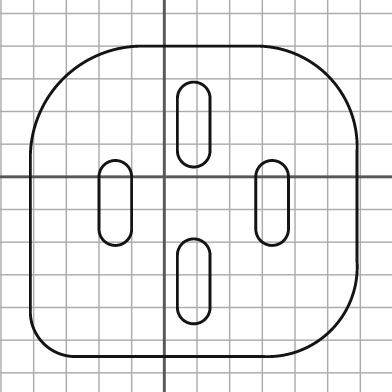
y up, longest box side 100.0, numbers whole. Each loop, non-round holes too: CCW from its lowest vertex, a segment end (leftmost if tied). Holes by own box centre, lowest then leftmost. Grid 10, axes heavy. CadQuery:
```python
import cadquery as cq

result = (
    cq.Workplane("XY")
    .moveTo(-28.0, -55.0)
    .lineTo(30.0, -55.0)
    .threePointArc((51.0, -47.0), (59.0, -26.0))
    .lineTo(59.0, 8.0)
    .threePointArc((50.0, 31.0), (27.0, 40.0))
    .lineTo(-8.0, 40.0)
    .threePointArc((-31.0, 30.0), (-41.0, 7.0))
    .lineTo(-41.0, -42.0)
    .threePointArc((-37.0, -51.0), (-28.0, -55.0))
    .close()
    .moveTo(4.0, -40.0)
    .threePointArc((9.0, -45.0), (14.0, -40.0))
    .lineTo(14.0, -24.0)
    .threePointArc((9.0, -19.0), (4.0, -24.0))
    .close()
    .moveTo(-20.0, -16.0)
    .threePointArc((-15.0, -21.0), (-10.0, -16.0))
    .lineTo(-10.0, 0.0)
    .threePointArc((-15.0, 5.0), (-20.0, 0.0))
    .close()
    .moveTo(28.0, -16.0)
    .threePointArc((33.0, -21.0), (38.0, -16.0))
    .lineTo(38.0, 0.0)
    .threePointArc((33.0, 5.0), (28.0, 0.0))
    .close()
    .moveTo(4.0, 8.0)
    .threePointArc((9.0, 3.0), (14.0, 8.0))
    .lineTo(14.0, 24.0)
    .threePointArc((9.0, 29.0), (4.0, 24.0))
    .close()
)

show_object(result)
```